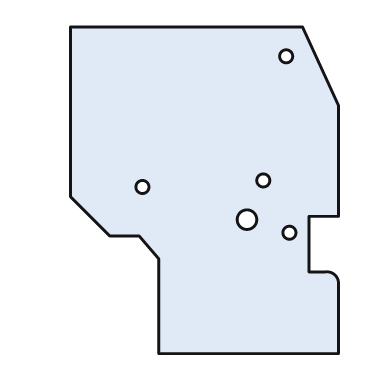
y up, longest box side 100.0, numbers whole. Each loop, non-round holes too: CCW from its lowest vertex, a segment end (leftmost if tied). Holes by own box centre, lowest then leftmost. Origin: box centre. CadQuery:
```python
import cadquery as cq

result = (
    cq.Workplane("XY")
    .moveTo(-14.0, -50.0)
    .lineTo(41.0, -50.0)
    .lineTo(41.0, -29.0)
    .threePointArc((40.0, -26.0), (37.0, -25.0))
    .lineTo(32.0, -25.0)
    .lineTo(32.0, -8.0)
    .lineTo(41.0, -8.0)
    .lineTo(41.0, 26.0)
    .lineTo(30.0, 50.0)
    .lineTo(-41.0, 50.0)
    .lineTo(-41.0, -2.0)
    .lineTo(-29.0, -14.0)
    .lineTo(-20.0, -14.0)
    .lineTo(-14.0, -21.0)
    .close()
    .moveTo(26.0, -13.0)
    .circle(2.0)
    .moveTo(13.0, -9.0)
    .circle(3.0)
    .moveTo(-19.0, 1.0)
    .circle(2.0)
    .moveTo(18.0, 3.0)
    .circle(2.0)
    .moveTo(25.0, 41.0)
    .circle(2.0)
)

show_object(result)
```